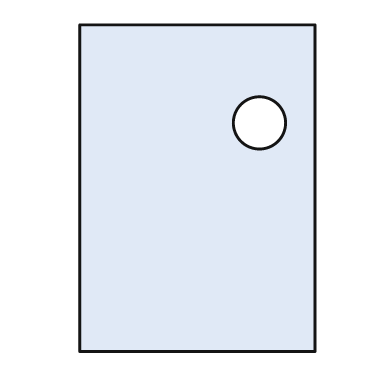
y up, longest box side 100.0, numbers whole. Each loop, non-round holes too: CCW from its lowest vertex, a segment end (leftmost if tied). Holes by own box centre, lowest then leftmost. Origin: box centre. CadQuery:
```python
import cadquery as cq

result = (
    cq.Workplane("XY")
    .moveTo(-36.0, -50.0)
    .lineTo(36.0, -50.0)
    .lineTo(36.0, 50.0)
    .lineTo(-36.0, 50.0)
    .close()
    .moveTo(19.0, 20.0)
    .circle(8.0)
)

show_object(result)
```